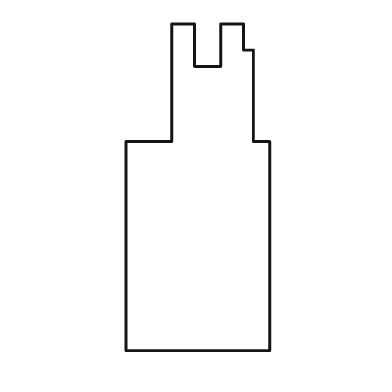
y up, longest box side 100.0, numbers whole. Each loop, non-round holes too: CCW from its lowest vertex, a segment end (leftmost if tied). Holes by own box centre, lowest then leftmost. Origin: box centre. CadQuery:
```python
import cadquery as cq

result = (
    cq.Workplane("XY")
    .moveTo(-22.0, -50.0)
    .lineTo(22.0, -50.0)
    .lineTo(22.0, 14.0)
    .lineTo(17.0, 14.0)
    .lineTo(17.0, 42.0)
    .lineTo(14.0, 42.0)
    .lineTo(14.0, 50.0)
    .lineTo(7.0, 50.0)
    .lineTo(7.0, 37.0)
    .lineTo(-1.0, 37.0)
    .lineTo(-1.0, 50.0)
    .lineTo(-8.0, 50.0)
    .lineTo(-8.0, 14.0)
    .lineTo(-22.0, 14.0)
    .close()
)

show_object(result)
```